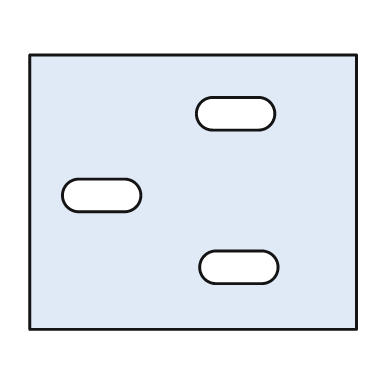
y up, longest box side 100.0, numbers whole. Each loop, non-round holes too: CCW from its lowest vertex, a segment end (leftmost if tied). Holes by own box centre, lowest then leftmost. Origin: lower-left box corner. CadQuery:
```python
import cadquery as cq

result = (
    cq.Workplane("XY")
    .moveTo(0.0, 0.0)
    .lineTo(100.0, 0.0)
    .lineTo(100.0, 84.0)
    .lineTo(0.0, 84.0)
    .close()
    .moveTo(57.0, 14.0)
    .lineTo(71.0, 14.0)
    .threePointArc((76.0, 19.0), (71.0, 24.0))
    .lineTo(57.0, 24.0)
    .threePointArc((52.0, 19.0), (57.0, 14.0))
    .close()
    .moveTo(15.0, 36.0)
    .lineTo(29.0, 36.0)
    .threePointArc((34.0, 41.0), (29.0, 46.0))
    .lineTo(15.0, 46.0)
    .threePointArc((10.0, 41.0), (15.0, 36.0))
    .close()
    .moveTo(56.0, 61.0)
    .lineTo(70.0, 61.0)
    .threePointArc((75.0, 66.0), (70.0, 71.0))
    .lineTo(56.0, 71.0)
    .threePointArc((51.0, 66.0), (56.0, 61.0))
    .close()
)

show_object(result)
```